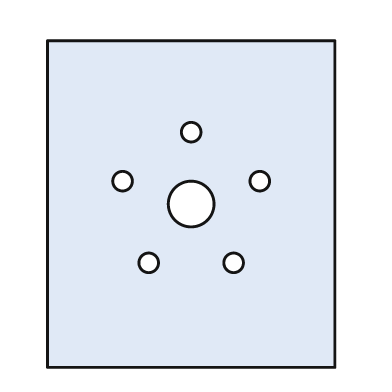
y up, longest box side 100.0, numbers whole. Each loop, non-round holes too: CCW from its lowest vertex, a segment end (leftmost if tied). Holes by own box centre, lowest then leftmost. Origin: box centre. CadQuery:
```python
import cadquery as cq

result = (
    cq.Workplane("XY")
    .moveTo(-44.0, -50.0)
    .lineTo(44.0, -50.0)
    .lineTo(44.0, 50.0)
    .lineTo(-44.0, 50.0)
    .close()
    .moveTo(-13.0, -18.0)
    .circle(3.0)
    .moveTo(13.0, -18.0)
    .circle(3.0)
    .moveTo(0.0, 0.0)
    .circle(7.0)
    .moveTo(-21.0, 7.0)
    .circle(3.0)
    .moveTo(21.0, 7.0)
    .circle(3.0)
    .moveTo(0.0, 22.0)
    .circle(3.0)
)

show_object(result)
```